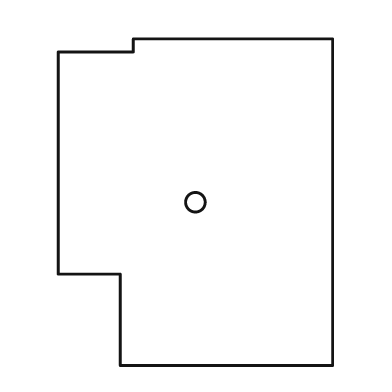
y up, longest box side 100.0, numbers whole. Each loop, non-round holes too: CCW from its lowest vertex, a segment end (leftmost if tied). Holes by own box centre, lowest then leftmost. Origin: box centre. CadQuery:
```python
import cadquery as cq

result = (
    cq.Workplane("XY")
    .moveTo(-23.0, -50.0)
    .lineTo(42.0, -50.0)
    .lineTo(42.0, 50.0)
    .lineTo(-19.0, 50.0)
    .lineTo(-19.0, 46.0)
    .lineTo(-42.0, 46.0)
    .lineTo(-42.0, -22.0)
    .lineTo(-23.0, -22.0)
    .close()
    .moveTo(0.0, 0.0)
    .circle(3.0)
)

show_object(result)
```